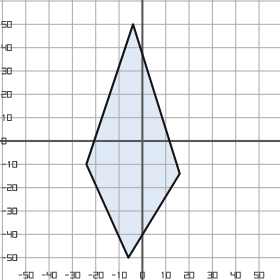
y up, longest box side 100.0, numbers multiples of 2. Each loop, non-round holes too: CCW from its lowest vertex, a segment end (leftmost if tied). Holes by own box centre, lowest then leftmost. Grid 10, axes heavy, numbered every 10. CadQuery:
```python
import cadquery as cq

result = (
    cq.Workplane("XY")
    .moveTo(-6.0, -50.0)
    .lineTo(16.0, -14.0)
    .lineTo(-4.0, 50.0)
    .lineTo(-24.0, -10.0)
    .close()
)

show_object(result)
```